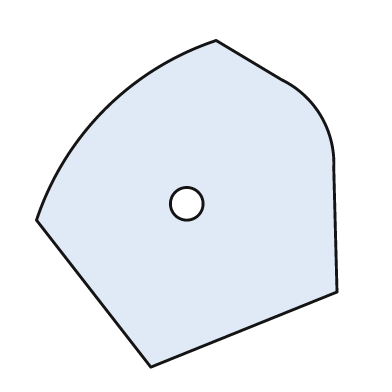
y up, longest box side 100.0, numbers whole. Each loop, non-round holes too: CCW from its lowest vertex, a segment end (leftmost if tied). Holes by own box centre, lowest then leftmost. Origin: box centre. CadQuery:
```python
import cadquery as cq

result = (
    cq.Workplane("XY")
    .moveTo(-11.0, -50.0)
    .lineTo(46.0, -27.0)
    .lineTo(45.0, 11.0)
    .threePointArc((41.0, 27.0), (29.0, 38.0))
    .lineTo(9.0, 50.0)
    .threePointArc((-25.0, 29.0), (-46.0, -5.0))
    .close()
    .moveTo(0.0, 0.0)
    .circle(5.0)
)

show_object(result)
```